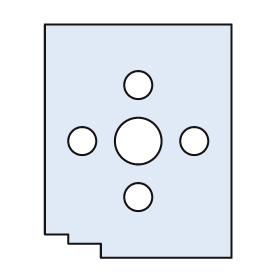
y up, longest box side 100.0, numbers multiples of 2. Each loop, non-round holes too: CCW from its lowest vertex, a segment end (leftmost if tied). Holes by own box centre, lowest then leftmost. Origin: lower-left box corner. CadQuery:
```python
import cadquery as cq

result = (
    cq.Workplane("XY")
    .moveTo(24.0, 0.0)
    .lineTo(80.0, 0.0)
    .lineTo(80.0, 100.0)
    .lineTo(0.0, 100.0)
    .lineTo(0.0, 10.0)
    .lineTo(10.0, 10.0)
    .lineTo(10.0, 6.0)
    .lineTo(24.0, 6.0)
    .close()
    .moveTo(40.0, 26.0)
    .circle(6.0)
    .moveTo(16.0, 50.0)
    .circle(6.0)
    .moveTo(40.0, 50.0)
    .circle(10.0)
    .moveTo(64.0, 50.0)
    .circle(6.0)
    .moveTo(40.0, 74.0)
    .circle(6.0)
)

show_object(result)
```